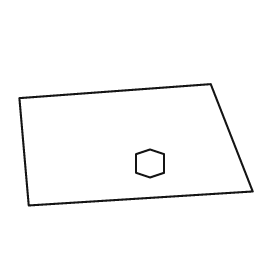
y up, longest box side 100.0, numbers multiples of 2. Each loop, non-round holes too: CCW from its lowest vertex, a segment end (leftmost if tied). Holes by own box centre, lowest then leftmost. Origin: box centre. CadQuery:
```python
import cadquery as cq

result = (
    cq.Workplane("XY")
    .moveTo(-46.0, -26.0)
    .lineTo(50.0, -20.0)
    .lineTo(32.0, 26.0)
    .lineTo(-50.0, 20.0)
    .close()
    .moveTo(6.0, -14.0)
    .lineTo(12.0, -12.0)
    .lineTo(12.0, -4.0)
    .lineTo(6.0, -2.0)
    .lineTo(0.0, -4.0)
    .lineTo(0.0, -12.0)
    .close()
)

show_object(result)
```